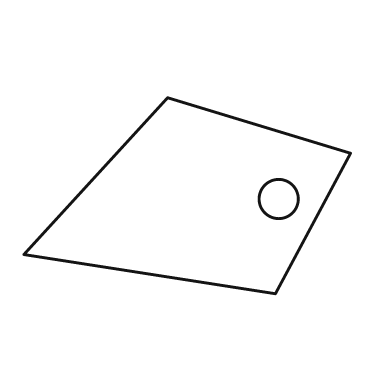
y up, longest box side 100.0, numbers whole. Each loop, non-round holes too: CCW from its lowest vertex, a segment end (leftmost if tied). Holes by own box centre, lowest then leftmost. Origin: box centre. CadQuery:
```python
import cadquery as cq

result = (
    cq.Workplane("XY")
    .moveTo(27.0, -30.0)
    .lineTo(50.0, 13.0)
    .lineTo(-6.0, 30.0)
    .lineTo(-50.0, -18.0)
    .close()
    .moveTo(28.0, -1.0)
    .circle(6.0)
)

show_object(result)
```